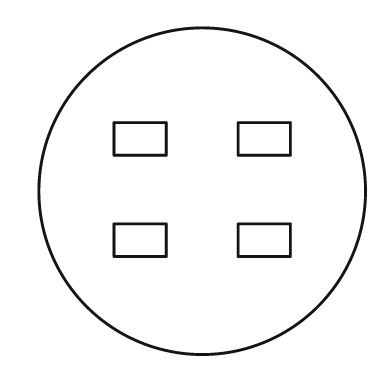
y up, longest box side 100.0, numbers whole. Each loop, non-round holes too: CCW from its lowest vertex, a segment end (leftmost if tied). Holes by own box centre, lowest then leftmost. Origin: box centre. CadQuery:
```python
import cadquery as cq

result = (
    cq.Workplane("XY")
    .moveTo(0.0, 0.0)
    .circle(50.0)
    .moveTo(-27.0, -20.0)
    .lineTo(-11.0, -20.0)
    .lineTo(-11.0, -10.0)
    .lineTo(-27.0, -10.0)
    .close()
    .moveTo(11.0, -20.0)
    .lineTo(27.0, -20.0)
    .lineTo(27.0, -10.0)
    .lineTo(11.0, -10.0)
    .close()
    .moveTo(-27.0, 11.0)
    .lineTo(-11.0, 11.0)
    .lineTo(-11.0, 21.0)
    .lineTo(-27.0, 21.0)
    .close()
    .moveTo(11.0, 11.0)
    .lineTo(27.0, 11.0)
    .lineTo(27.0, 21.0)
    .lineTo(11.0, 21.0)
    .close()
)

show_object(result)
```